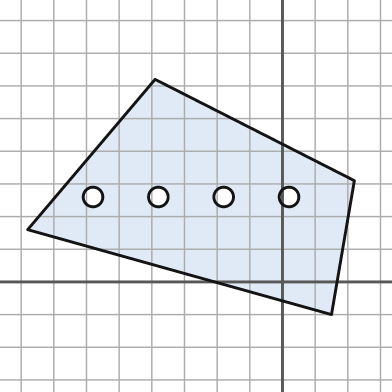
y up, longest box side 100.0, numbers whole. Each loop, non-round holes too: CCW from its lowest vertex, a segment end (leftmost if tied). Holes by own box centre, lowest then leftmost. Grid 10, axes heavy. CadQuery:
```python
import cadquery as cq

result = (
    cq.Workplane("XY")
    .moveTo(15.0, -10.0)
    .lineTo(22.0, 31.0)
    .lineTo(-39.0, 62.0)
    .lineTo(-78.0, 16.0)
    .close()
    .moveTo(-58.0, 26.0)
    .circle(3.0)
    .moveTo(-38.0, 26.0)
    .circle(3.0)
    .moveTo(-18.0, 26.0)
    .circle(3.0)
    .moveTo(2.0, 26.0)
    .circle(3.0)
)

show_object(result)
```